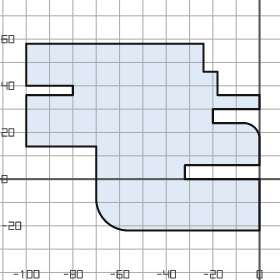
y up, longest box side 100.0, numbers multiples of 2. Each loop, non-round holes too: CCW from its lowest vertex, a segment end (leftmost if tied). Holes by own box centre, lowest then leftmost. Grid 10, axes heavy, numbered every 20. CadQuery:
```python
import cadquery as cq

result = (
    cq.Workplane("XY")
    .moveTo(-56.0, -22.0)
    .lineTo(0.0, -22.0)
    .lineTo(0.0, 0.0)
    .lineTo(-32.0, 0.0)
    .lineTo(-32.0, 6.0)
    .lineTo(0.0, 6.0)
    .lineTo(0.0, 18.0)
    .threePointArc((-2.0, 22.0), (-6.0, 24.0))
    .lineTo(-20.0, 24.0)
    .lineTo(-20.0, 30.0)
    .lineTo(0.0, 30.0)
    .lineTo(0.0, 36.0)
    .lineTo(-18.0, 36.0)
    .lineTo(-18.0, 46.0)
    .lineTo(-24.0, 46.0)
    .lineTo(-24.0, 58.0)
    .lineTo(-100.0, 58.0)
    .lineTo(-100.0, 40.0)
    .lineTo(-80.0, 40.0)
    .lineTo(-80.0, 36.0)
    .lineTo(-100.0, 36.0)
    .lineTo(-100.0, 14.0)
    .lineTo(-70.0, 14.0)
    .lineTo(-70.0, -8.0)
    .threePointArc((-66.0, -18.0), (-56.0, -22.0))
    .close()
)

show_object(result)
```